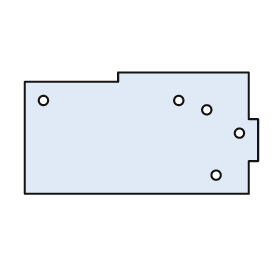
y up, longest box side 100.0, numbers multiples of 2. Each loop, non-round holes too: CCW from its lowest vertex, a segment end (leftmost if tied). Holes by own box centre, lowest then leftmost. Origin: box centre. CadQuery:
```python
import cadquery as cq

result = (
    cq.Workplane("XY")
    .moveTo(-50.0, -26.0)
    .lineTo(46.0, -26.0)
    .lineTo(46.0, -12.0)
    .lineTo(50.0, -12.0)
    .lineTo(50.0, 6.0)
    .lineTo(46.0, 6.0)
    .lineTo(46.0, 26.0)
    .lineTo(-10.0, 26.0)
    .lineTo(-10.0, 22.0)
    .lineTo(-50.0, 22.0)
    .close()
    .moveTo(32.0, -18.0)
    .circle(2.0)
    .moveTo(42.0, 0.0)
    .circle(2.0)
    .moveTo(28.0, 10.0)
    .circle(2.0)
    .moveTo(-42.0, 14.0)
    .circle(2.0)
    .moveTo(16.0, 14.0)
    .circle(2.0)
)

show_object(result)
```